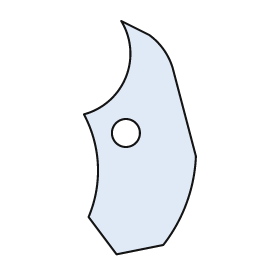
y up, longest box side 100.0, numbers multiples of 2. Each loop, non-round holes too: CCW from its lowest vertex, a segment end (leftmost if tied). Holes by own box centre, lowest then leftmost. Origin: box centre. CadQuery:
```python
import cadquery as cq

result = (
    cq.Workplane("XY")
    .moveTo(-10.0, -50.0)
    .lineTo(10.0, -46.0)
    .threePointArc((20.0, -28.0), (24.0, -8.0))
    .lineTo(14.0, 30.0)
    .threePointArc((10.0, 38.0), (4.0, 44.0))
    .lineTo(-8.0, 50.0)
    .threePointArc((-6.0, 26.0), (-24.0, 10.0))
    .threePointArc((-18.0, -12.0), (-22.0, -34.0))
    .close()
    .moveTo(-6.0, 2.0)
    .circle(6.0)
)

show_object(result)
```